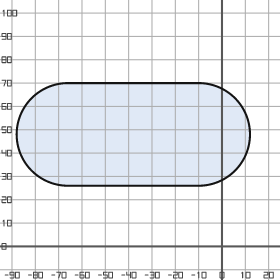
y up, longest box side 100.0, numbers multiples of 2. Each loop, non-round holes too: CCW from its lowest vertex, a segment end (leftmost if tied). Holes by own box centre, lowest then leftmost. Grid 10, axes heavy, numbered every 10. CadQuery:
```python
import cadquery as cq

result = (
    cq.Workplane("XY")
    .moveTo(-66.0, 26.0)
    .lineTo(-10.0, 26.0)
    .threePointArc((12.0, 48.0), (-10.0, 70.0))
    .lineTo(-66.0, 70.0)
    .threePointArc((-88.0, 48.0), (-66.0, 26.0))
    .close()
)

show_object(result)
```